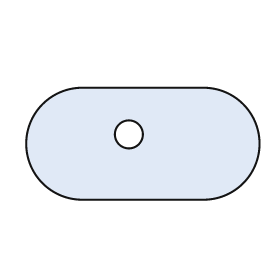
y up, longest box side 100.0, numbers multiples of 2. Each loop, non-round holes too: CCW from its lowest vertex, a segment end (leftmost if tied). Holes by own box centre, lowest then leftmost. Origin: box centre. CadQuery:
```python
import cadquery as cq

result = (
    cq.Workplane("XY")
    .moveTo(-26.0, -24.0)
    .lineTo(26.0, -24.0)
    .threePointArc((50.0, 0.0), (26.0, 24.0))
    .lineTo(-26.0, 24.0)
    .threePointArc((-50.0, 0.0), (-26.0, -24.0))
    .close()
    .moveTo(-6.0, 4.0)
    .circle(6.0)
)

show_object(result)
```